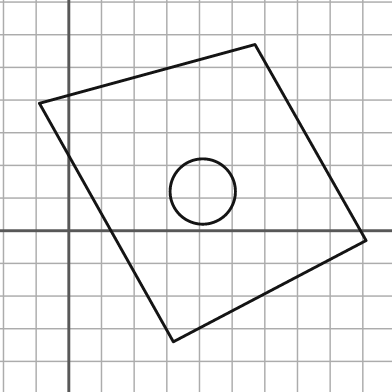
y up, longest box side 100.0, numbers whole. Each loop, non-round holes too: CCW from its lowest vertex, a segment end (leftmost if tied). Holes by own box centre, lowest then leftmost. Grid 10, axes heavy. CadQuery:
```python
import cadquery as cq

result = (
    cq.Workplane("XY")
    .moveTo(32.0, -34.0)
    .lineTo(91.0, -3.0)
    .lineTo(57.0, 57.0)
    .lineTo(-9.0, 39.0)
    .close()
    .moveTo(41.0, 12.0)
    .circle(10.0)
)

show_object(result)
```